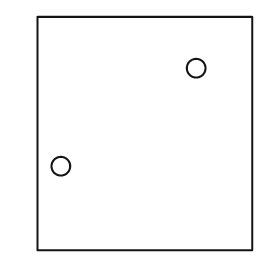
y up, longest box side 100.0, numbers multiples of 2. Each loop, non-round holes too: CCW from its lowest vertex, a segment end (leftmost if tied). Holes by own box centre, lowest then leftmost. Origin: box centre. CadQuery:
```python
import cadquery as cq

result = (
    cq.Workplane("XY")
    .moveTo(-46.0, -50.0)
    .lineTo(46.0, -50.0)
    .lineTo(46.0, 50.0)
    .lineTo(-46.0, 50.0)
    .close()
    .moveTo(-36.0, -14.0)
    .circle(4.0)
    .moveTo(22.0, 28.0)
    .circle(4.0)
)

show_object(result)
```